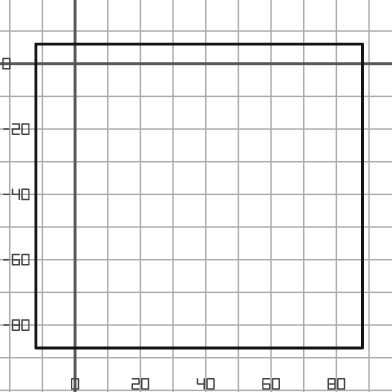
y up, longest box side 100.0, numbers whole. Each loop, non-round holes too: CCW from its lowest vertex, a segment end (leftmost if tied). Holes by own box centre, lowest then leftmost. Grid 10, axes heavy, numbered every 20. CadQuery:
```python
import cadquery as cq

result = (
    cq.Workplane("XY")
    .moveTo(-12.0, -87.0)
    .lineTo(88.0, -87.0)
    .lineTo(88.0, 6.0)
    .lineTo(-12.0, 6.0)
    .close()
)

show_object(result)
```